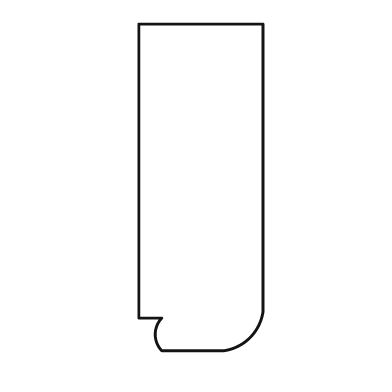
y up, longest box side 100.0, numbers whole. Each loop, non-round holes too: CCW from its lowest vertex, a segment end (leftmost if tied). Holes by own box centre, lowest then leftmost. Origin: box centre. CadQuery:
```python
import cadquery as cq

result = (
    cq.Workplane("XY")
    .moveTo(-12.0, -50.0)
    .lineTo(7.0, -50.0)
    .threePointArc((15.0, -46.0), (19.0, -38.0))
    .lineTo(19.0, 50.0)
    .lineTo(-19.0, 50.0)
    .lineTo(-19.0, -40.0)
    .lineTo(-12.0, -40.0)
    .threePointArc((-14.0, -45.0), (-12.0, -50.0))
    .close()
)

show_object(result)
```